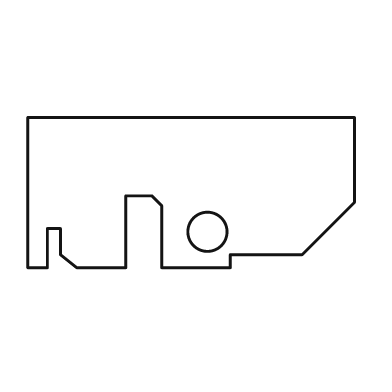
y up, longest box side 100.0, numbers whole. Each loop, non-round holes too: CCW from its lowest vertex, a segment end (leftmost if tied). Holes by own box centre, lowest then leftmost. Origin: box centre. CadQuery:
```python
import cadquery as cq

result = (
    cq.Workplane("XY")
    .moveTo(-50.0, -23.0)
    .lineTo(-44.0, -23.0)
    .lineTo(-44.0, -11.0)
    .lineTo(-40.0, -11.0)
    .lineTo(-40.0, -19.0)
    .lineTo(-35.0, -23.0)
    .lineTo(-20.0, -23.0)
    .lineTo(-20.0, -1.0)
    .lineTo(-12.0, -1.0)
    .lineTo(-9.0, -4.0)
    .lineTo(-9.0, -23.0)
    .lineTo(12.0, -23.0)
    .lineTo(12.0, -19.0)
    .lineTo(34.0, -19.0)
    .lineTo(50.0, -3.0)
    .lineTo(50.0, 23.0)
    .lineTo(-50.0, 23.0)
    .close()
    .moveTo(5.0, -12.0)
    .circle(6.0)
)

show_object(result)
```